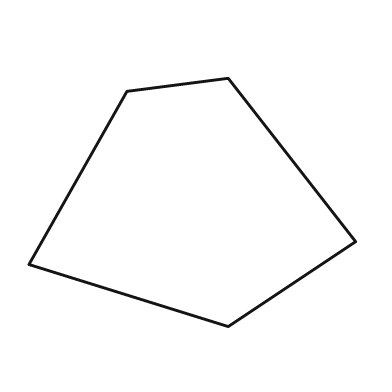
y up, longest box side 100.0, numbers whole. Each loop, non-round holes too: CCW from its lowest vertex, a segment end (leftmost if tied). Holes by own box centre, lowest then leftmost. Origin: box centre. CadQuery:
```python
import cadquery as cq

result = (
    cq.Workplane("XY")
    .moveTo(11.0, -38.0)
    .lineTo(50.0, -12.0)
    .lineTo(11.0, 38.0)
    .lineTo(-20.0, 34.0)
    .lineTo(-50.0, -19.0)
    .close()
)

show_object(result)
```